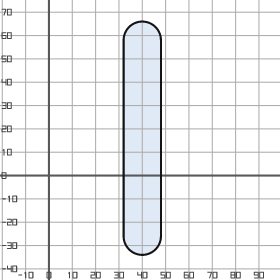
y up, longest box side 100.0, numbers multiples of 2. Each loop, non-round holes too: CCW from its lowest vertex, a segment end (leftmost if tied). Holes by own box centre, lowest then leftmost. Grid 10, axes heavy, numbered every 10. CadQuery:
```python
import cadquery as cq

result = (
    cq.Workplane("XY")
    .moveTo(32.0, -26.0)
    .threePointArc((40.0, -34.0), (48.0, -26.0))
    .lineTo(48.0, 58.0)
    .threePointArc((40.0, 66.0), (32.0, 58.0))
    .close()
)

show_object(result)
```